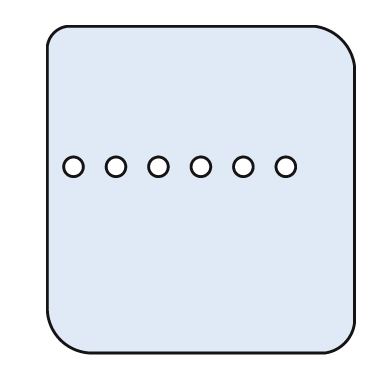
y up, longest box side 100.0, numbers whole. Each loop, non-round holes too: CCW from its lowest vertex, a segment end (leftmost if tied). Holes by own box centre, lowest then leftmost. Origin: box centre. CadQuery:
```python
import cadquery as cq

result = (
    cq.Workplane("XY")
    .moveTo(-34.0, -50.0)
    .lineTo(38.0, -50.0)
    .threePointArc((44.0, -47.0), (47.0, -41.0))
    .lineTo(47.0, 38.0)
    .threePointArc((43.0, 46.0), (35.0, 50.0))
    .lineTo(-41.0, 50.0)
    .threePointArc((-45.0, 48.0), (-47.0, 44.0))
    .lineTo(-47.0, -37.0)
    .threePointArc((-43.0, -46.0), (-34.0, -50.0))
    .close()
    .moveTo(-39.0, 7.0)
    .circle(3.0)
    .moveTo(-26.0, 7.0)
    .circle(3.0)
    .moveTo(-13.0, 7.0)
    .circle(3.0)
    .moveTo(0.0, 7.0)
    .circle(3.0)
    .moveTo(13.0, 7.0)
    .circle(3.0)
    .moveTo(26.0, 7.0)
    .circle(3.0)
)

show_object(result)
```